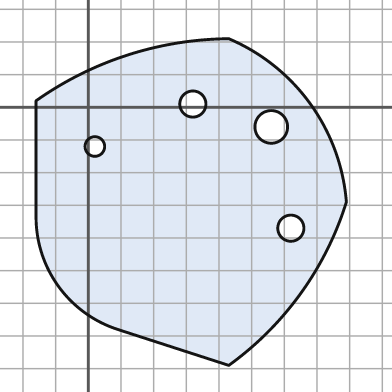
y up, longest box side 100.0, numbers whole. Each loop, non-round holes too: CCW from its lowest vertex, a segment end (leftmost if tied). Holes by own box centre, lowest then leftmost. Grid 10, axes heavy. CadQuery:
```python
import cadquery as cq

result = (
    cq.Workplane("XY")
    .moveTo(43.0, -79.0)
    .threePointArc((65.0, -57.0), (79.0, -29.0))
    .threePointArc((68.0, 1.0), (43.0, 21.0))
    .threePointArc((12.0, 16.0), (-16.0, 2.0))
    .lineTo(-16.0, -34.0)
    .threePointArc((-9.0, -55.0), (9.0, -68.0))
    .close()
    .moveTo(62.0, -37.0)
    .circle(4.0)
    .moveTo(2.0, -12.0)
    .circle(3.0)
    .moveTo(56.0, -6.0)
    .circle(5.0)
    .moveTo(32.0, 1.0)
    .circle(4.0)
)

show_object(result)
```